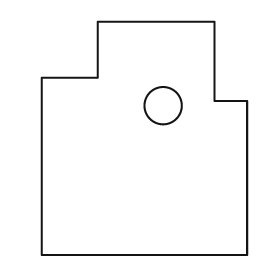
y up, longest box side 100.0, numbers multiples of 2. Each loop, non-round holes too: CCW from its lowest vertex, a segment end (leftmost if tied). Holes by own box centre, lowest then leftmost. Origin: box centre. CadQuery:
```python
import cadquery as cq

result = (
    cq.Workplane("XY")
    .moveTo(-44.0, -50.0)
    .lineTo(44.0, -50.0)
    .lineTo(44.0, 16.0)
    .lineTo(30.0, 16.0)
    .lineTo(30.0, 50.0)
    .lineTo(-20.0, 50.0)
    .lineTo(-20.0, 26.0)
    .lineTo(-44.0, 26.0)
    .close()
    .moveTo(8.0, 14.0)
    .circle(8.0)
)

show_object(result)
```